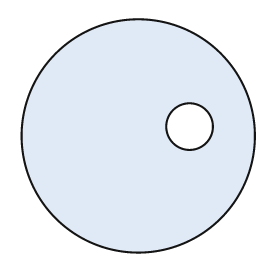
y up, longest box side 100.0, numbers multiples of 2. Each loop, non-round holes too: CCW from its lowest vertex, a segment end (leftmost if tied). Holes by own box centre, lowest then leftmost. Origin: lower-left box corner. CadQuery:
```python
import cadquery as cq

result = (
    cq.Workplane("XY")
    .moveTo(50.0, 50.0)
    .circle(50.0)
    .moveTo(72.0, 54.0)
    .circle(10.0)
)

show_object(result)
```